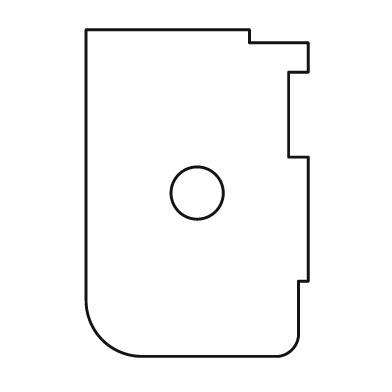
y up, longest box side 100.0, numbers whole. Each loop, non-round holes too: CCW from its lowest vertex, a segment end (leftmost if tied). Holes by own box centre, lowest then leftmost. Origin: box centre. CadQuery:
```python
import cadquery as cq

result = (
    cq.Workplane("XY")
    .moveTo(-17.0, -50.0)
    .lineTo(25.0, -50.0)
    .threePointArc((29.0, -48.0), (31.0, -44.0))
    .lineTo(31.0, -27.0)
    .lineTo(34.0, -27.0)
    .lineTo(34.0, 11.0)
    .lineTo(28.0, 11.0)
    .lineTo(28.0, 37.0)
    .lineTo(34.0, 37.0)
    .lineTo(34.0, 46.0)
    .lineTo(16.0, 46.0)
    .lineTo(16.0, 50.0)
    .lineTo(-34.0, 50.0)
    .lineTo(-34.0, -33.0)
    .threePointArc((-29.0, -45.0), (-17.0, -50.0))
    .close()
    .moveTo(0.0, 0.0)
    .circle(8.0)
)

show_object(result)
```